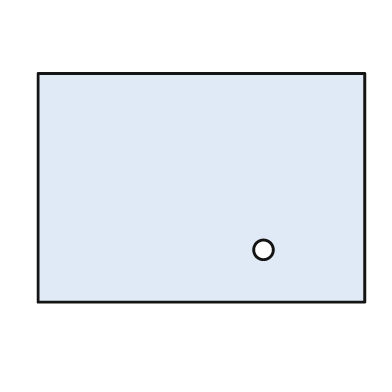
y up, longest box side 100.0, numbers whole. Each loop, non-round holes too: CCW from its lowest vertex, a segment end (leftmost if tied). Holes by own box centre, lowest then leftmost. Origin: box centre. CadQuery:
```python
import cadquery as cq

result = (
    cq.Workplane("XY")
    .moveTo(-50.0, -35.0)
    .lineTo(50.0, -35.0)
    .lineTo(50.0, 35.0)
    .lineTo(-50.0, 35.0)
    .close()
    .moveTo(19.0, -19.0)
    .circle(3.0)
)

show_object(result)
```